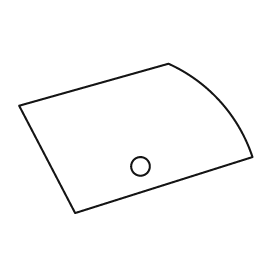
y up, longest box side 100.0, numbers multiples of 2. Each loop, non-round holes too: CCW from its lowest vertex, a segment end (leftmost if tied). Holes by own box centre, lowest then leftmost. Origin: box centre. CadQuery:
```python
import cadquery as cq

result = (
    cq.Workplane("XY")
    .moveTo(-26.0, -32.0)
    .lineTo(50.0, -8.0)
    .threePointArc((36.0, 16.0), (14.0, 32.0))
    .lineTo(-50.0, 14.0)
    .close()
    .moveTo(2.0, -12.0)
    .circle(4.0)
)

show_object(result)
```